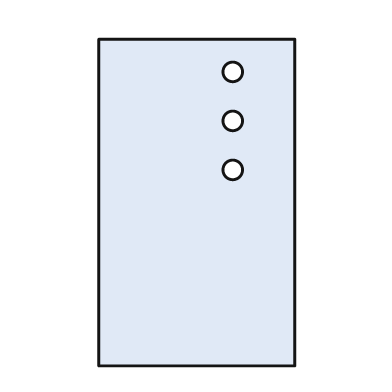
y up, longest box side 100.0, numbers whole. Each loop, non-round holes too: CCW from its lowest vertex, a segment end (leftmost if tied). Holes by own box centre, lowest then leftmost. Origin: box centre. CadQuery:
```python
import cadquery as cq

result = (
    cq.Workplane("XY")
    .moveTo(-30.0, -50.0)
    .lineTo(30.0, -50.0)
    .lineTo(30.0, 50.0)
    .lineTo(-30.0, 50.0)
    .close()
    .moveTo(11.0, 10.0)
    .circle(3.0)
    .moveTo(11.0, 25.0)
    .circle(3.0)
    .moveTo(11.0, 40.0)
    .circle(3.0)
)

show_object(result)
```